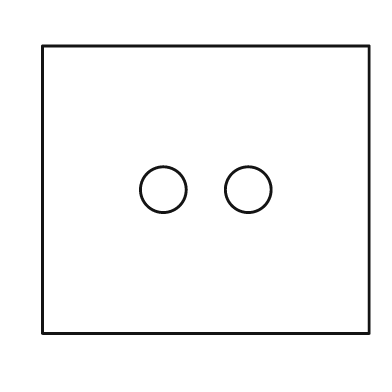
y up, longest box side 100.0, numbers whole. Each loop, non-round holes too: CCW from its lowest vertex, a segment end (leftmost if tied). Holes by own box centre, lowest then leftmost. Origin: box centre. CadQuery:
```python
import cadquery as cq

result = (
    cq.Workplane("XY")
    .moveTo(-50.0, -44.0)
    .lineTo(50.0, -44.0)
    .lineTo(50.0, 44.0)
    .lineTo(-50.0, 44.0)
    .close()
    .moveTo(-13.0, 0.0)
    .circle(7.0)
    .moveTo(13.0, 0.0)
    .circle(7.0)
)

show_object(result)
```